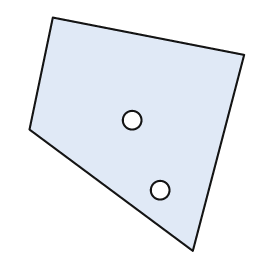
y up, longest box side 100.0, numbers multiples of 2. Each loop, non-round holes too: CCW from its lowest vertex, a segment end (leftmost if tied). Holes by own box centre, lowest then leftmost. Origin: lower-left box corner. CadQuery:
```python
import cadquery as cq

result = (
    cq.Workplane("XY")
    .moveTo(70.0, 0.0)
    .lineTo(92.0, 84.0)
    .lineTo(10.0, 100.0)
    .lineTo(0.0, 52.0)
    .close()
    .moveTo(56.0, 26.0)
    .circle(4.0)
    .moveTo(44.0, 56.0)
    .circle(4.0)
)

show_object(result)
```